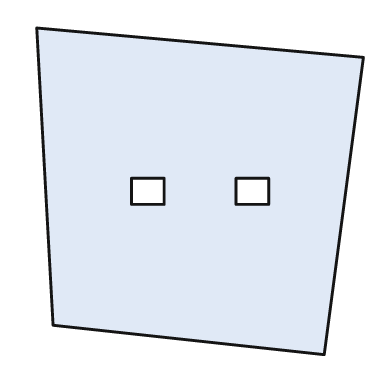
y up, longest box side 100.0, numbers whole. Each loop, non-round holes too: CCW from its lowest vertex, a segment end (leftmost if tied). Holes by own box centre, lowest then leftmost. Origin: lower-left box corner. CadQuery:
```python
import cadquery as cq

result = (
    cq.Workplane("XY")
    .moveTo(88.0, 0.0)
    .lineTo(100.0, 91.0)
    .lineTo(0.0, 100.0)
    .lineTo(5.0, 9.0)
    .close()
    .moveTo(29.0, 46.0)
    .lineTo(39.0, 46.0)
    .lineTo(39.0, 54.0)
    .lineTo(29.0, 54.0)
    .close()
    .moveTo(61.0, 46.0)
    .lineTo(71.0, 46.0)
    .lineTo(71.0, 54.0)
    .lineTo(61.0, 54.0)
    .close()
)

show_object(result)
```